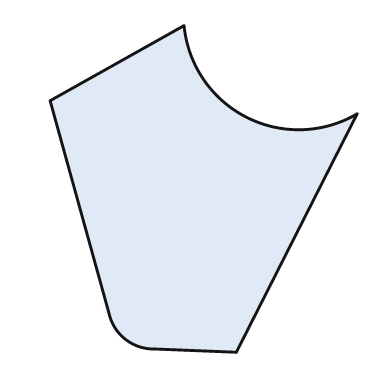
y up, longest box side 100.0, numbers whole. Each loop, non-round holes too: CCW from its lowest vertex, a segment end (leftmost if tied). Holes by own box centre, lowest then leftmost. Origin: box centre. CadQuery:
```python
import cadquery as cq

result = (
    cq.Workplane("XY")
    .moveTo(10.0, -50.0)
    .lineTo(47.0, 23.0)
    .threePointArc((13.0, 22.0), (-6.0, 50.0))
    .lineTo(-47.0, 27.0)
    .lineTo(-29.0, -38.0)
    .threePointArc((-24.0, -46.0), (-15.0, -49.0))
    .close()
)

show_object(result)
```